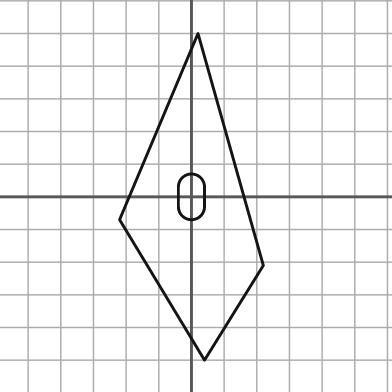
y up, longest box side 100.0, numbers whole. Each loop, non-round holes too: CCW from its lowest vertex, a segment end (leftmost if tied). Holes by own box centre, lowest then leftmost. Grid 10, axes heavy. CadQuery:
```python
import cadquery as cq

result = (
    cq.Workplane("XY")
    .moveTo(4.0, -50.0)
    .lineTo(22.0, -21.0)
    .lineTo(2.0, 50.0)
    .lineTo(-22.0, -7.0)
    .close()
    .moveTo(-4.0, -3.0)
    .threePointArc((0.0, -7.0), (4.0, -3.0))
    .lineTo(4.0, 3.0)
    .threePointArc((0.0, 7.0), (-4.0, 3.0))
    .close()
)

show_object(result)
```